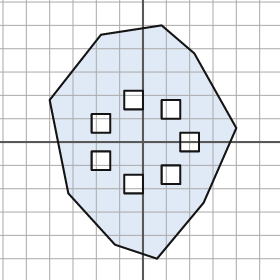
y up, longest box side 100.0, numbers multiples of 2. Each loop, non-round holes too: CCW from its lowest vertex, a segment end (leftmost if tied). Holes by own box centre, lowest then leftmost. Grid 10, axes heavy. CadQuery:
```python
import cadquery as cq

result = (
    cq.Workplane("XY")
    .moveTo(6.0, -50.0)
    .lineTo(26.0, -26.0)
    .lineTo(40.0, 6.0)
    .lineTo(22.0, 38.0)
    .lineTo(8.0, 50.0)
    .lineTo(-18.0, 46.0)
    .lineTo(-40.0, 18.0)
    .lineTo(-32.0, -22.0)
    .lineTo(-12.0, -44.0)
    .close()
    .moveTo(-8.0, -22.0)
    .lineTo(0.0, -22.0)
    .lineTo(0.0, -14.0)
    .lineTo(-8.0, -14.0)
    .close()
    .moveTo(8.0, -18.0)
    .lineTo(16.0, -18.0)
    .lineTo(16.0, -10.0)
    .lineTo(8.0, -10.0)
    .close()
    .moveTo(-22.0, -12.0)
    .lineTo(-14.0, -12.0)
    .lineTo(-14.0, -4.0)
    .lineTo(-22.0, -4.0)
    .close()
    .moveTo(16.0, -4.0)
    .lineTo(24.0, -4.0)
    .lineTo(24.0, 4.0)
    .lineTo(16.0, 4.0)
    .close()
    .moveTo(-22.0, 4.0)
    .lineTo(-14.0, 4.0)
    .lineTo(-14.0, 12.0)
    .lineTo(-22.0, 12.0)
    .close()
    .moveTo(8.0, 10.0)
    .lineTo(16.0, 10.0)
    .lineTo(16.0, 18.0)
    .lineTo(8.0, 18.0)
    .close()
    .moveTo(-8.0, 14.0)
    .lineTo(0.0, 14.0)
    .lineTo(0.0, 22.0)
    .lineTo(-8.0, 22.0)
    .close()
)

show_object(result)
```